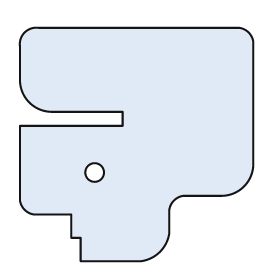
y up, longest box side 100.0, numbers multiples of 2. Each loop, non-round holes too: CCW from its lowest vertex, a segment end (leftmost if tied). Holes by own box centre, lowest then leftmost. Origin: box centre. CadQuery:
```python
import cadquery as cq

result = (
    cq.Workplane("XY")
    .moveTo(-24.0, -50.0)
    .lineTo(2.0, -50.0)
    .threePointArc((10.0, -46.0), (14.0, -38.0))
    .lineTo(14.0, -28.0)
    .threePointArc((16.0, -24.0), (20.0, -22.0))
    .lineTo(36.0, -22.0)
    .threePointArc((46.0, -18.0), (50.0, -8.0))
    .lineTo(50.0, 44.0)
    .threePointArc((48.0, 48.0), (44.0, 50.0))
    .lineTo(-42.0, 50.0)
    .threePointArc((-48.0, 48.0), (-50.0, 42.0))
    .lineTo(-50.0, 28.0)
    .threePointArc((-46.0, 18.0), (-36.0, 14.0))
    .lineTo(-6.0, 14.0)
    .lineTo(-6.0, 8.0)
    .lineTo(-50.0, 8.0)
    .lineTo(-50.0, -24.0)
    .threePointArc((-48.0, -28.0), (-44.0, -30.0))
    .lineTo(-28.0, -30.0)
    .lineTo(-28.0, -40.0)
    .lineTo(-24.0, -40.0)
    .close()
    .moveTo(-18.0, -12.0)
    .circle(4.0)
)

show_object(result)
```